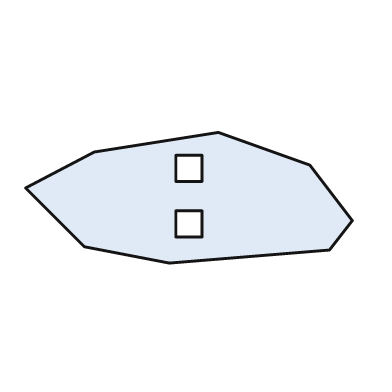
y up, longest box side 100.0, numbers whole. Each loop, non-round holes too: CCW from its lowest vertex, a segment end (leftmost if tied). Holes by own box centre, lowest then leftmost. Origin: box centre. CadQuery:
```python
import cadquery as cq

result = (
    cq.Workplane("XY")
    .moveTo(-6.0, -20.0)
    .lineTo(43.0, -16.0)
    .lineTo(50.0, -7.0)
    .lineTo(37.0, 10.0)
    .lineTo(9.0, 20.0)
    .lineTo(-29.0, 14.0)
    .lineTo(-50.0, 3.0)
    .lineTo(-32.0, -15.0)
    .close()
    .moveTo(-4.0, -12.0)
    .lineTo(4.0, -12.0)
    .lineTo(4.0, -4.0)
    .lineTo(-4.0, -4.0)
    .close()
    .moveTo(-4.0, 5.0)
    .lineTo(4.0, 5.0)
    .lineTo(4.0, 13.0)
    .lineTo(-4.0, 13.0)
    .close()
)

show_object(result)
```